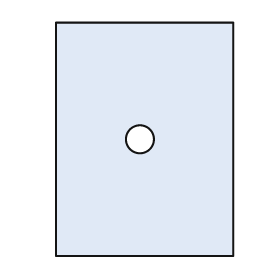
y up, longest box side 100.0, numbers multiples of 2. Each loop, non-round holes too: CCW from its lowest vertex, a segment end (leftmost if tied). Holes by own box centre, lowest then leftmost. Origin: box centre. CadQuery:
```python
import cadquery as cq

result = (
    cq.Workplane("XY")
    .moveTo(-38.0, -50.0)
    .lineTo(38.0, -50.0)
    .lineTo(38.0, 50.0)
    .lineTo(-38.0, 50.0)
    .close()
    .moveTo(-2.0, 0.0)
    .circle(6.0)
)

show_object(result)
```